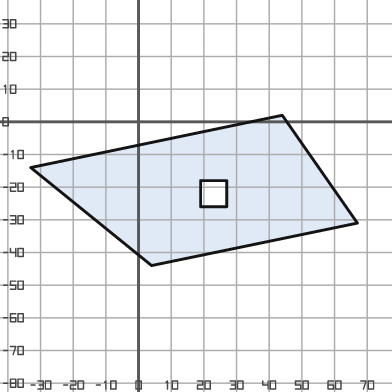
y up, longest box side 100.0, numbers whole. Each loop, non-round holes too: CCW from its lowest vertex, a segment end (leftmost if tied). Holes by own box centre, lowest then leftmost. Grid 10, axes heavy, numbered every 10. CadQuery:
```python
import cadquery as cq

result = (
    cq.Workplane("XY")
    .moveTo(4.0, -44.0)
    .lineTo(67.0, -31.0)
    .lineTo(44.0, 2.0)
    .lineTo(-33.0, -14.0)
    .close()
    .moveTo(19.0, -26.0)
    .lineTo(27.0, -26.0)
    .lineTo(27.0, -18.0)
    .lineTo(19.0, -18.0)
    .close()
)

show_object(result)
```